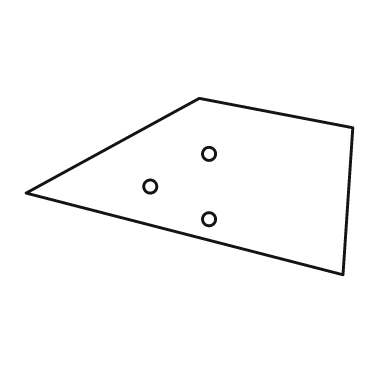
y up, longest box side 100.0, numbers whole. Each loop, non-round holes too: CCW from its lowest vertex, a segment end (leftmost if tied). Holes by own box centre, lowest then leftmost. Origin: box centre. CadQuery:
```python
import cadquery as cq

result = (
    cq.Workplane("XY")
    .moveTo(47.0, -27.0)
    .lineTo(50.0, 18.0)
    .lineTo(3.0, 27.0)
    .lineTo(-50.0, -2.0)
    .close()
    .moveTo(6.0, -10.0)
    .circle(2.0)
    .moveTo(-12.0, 0.0)
    .circle(2.0)
    .moveTo(6.0, 10.0)
    .circle(2.0)
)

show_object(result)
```